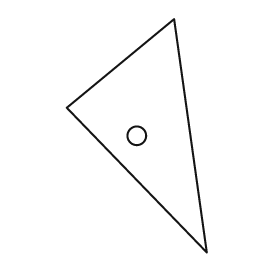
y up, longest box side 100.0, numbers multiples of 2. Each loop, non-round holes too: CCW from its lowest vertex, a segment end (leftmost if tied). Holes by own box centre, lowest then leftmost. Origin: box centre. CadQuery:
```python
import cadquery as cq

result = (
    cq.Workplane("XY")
    .moveTo(30.0, -50.0)
    .lineTo(16.0, 50.0)
    .lineTo(-30.0, 12.0)
    .close()
    .moveTo(0.0, 0.0)
    .circle(4.0)
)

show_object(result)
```